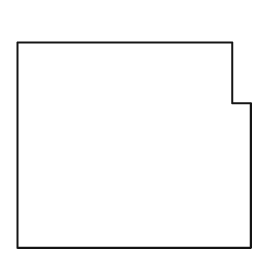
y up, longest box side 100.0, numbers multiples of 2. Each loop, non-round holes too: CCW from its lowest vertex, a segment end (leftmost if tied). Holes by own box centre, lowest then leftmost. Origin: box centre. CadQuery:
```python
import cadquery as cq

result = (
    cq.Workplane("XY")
    .moveTo(-50.0, -44.0)
    .lineTo(50.0, -44.0)
    .lineTo(50.0, 18.0)
    .lineTo(42.0, 18.0)
    .lineTo(42.0, 44.0)
    .lineTo(-50.0, 44.0)
    .close()
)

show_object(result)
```